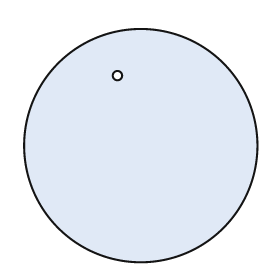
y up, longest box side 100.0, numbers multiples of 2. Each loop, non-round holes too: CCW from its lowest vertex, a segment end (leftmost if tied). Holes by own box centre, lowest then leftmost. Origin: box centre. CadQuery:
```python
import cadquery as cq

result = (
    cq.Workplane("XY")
    .moveTo(0.0, 0.0)
    .circle(50.0)
    .moveTo(-10.0, 30.0)
    .circle(2.0)
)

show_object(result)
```